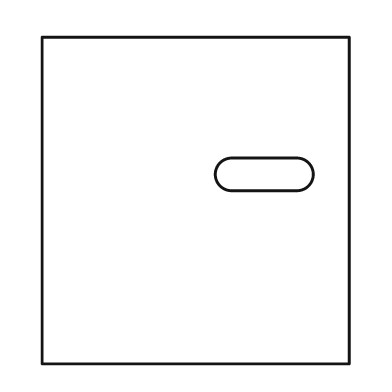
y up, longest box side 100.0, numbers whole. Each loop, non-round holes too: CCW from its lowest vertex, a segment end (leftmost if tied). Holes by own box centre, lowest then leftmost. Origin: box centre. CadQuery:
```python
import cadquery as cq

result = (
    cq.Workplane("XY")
    .moveTo(-47.0, -50.0)
    .lineTo(47.0, -50.0)
    .lineTo(47.0, 50.0)
    .lineTo(-47.0, 50.0)
    .close()
    .moveTo(11.0, 3.0)
    .lineTo(31.0, 3.0)
    .threePointArc((36.0, 8.0), (31.0, 13.0))
    .lineTo(11.0, 13.0)
    .threePointArc((6.0, 8.0), (11.0, 3.0))
    .close()
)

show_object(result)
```